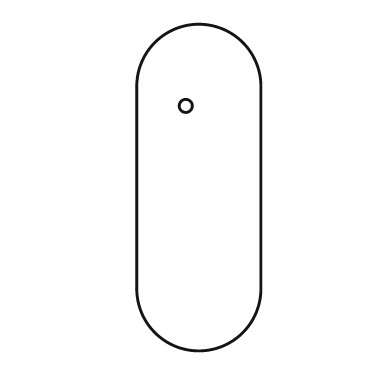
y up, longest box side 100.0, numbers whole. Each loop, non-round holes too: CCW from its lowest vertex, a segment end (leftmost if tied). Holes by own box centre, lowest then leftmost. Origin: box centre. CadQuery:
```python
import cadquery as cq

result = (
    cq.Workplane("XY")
    .moveTo(-19.0, -31.0)
    .threePointArc((0.0, -50.0), (19.0, -31.0))
    .lineTo(19.0, 31.0)
    .threePointArc((0.0, 50.0), (-19.0, 31.0))
    .close()
    .moveTo(-4.0, 25.0)
    .circle(2.0)
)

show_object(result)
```